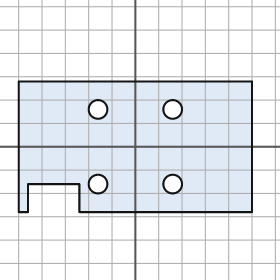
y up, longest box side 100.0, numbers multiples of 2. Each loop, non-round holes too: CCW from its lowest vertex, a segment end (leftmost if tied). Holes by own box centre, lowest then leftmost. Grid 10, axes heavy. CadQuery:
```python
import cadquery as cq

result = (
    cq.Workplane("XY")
    .moveTo(-50.0, -28.0)
    .lineTo(-46.0, -28.0)
    .lineTo(-46.0, -16.0)
    .lineTo(-24.0, -16.0)
    .lineTo(-24.0, -28.0)
    .lineTo(50.0, -28.0)
    .lineTo(50.0, 28.0)
    .lineTo(-50.0, 28.0)
    .close()
    .moveTo(-16.0, -16.0)
    .circle(4.0)
    .moveTo(16.0, -16.0)
    .circle(4.0)
    .moveTo(-16.0, 16.0)
    .circle(4.0)
    .moveTo(16.0, 16.0)
    .circle(4.0)
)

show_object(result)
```